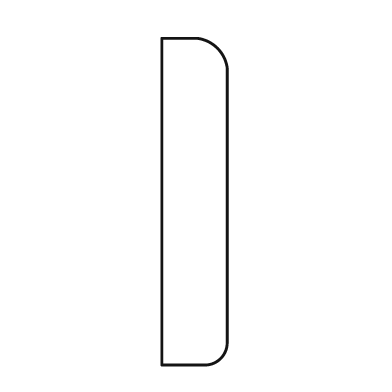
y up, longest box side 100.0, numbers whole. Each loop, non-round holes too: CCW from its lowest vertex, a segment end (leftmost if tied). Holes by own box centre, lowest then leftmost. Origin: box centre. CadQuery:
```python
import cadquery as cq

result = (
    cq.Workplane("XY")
    .moveTo(-10.0, -50.0)
    .lineTo(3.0, -50.0)
    .threePointArc((8.0, -48.0), (10.0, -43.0))
    .lineTo(10.0, 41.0)
    .threePointArc((7.0, 47.0), (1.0, 50.0))
    .lineTo(-10.0, 50.0)
    .close()
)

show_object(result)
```